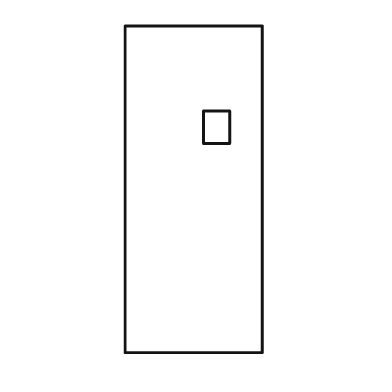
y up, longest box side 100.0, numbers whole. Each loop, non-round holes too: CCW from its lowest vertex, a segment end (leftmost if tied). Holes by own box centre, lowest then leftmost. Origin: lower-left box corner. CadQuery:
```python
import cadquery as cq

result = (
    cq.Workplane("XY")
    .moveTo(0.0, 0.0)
    .lineTo(42.0, 0.0)
    .lineTo(42.0, 100.0)
    .lineTo(0.0, 100.0)
    .close()
    .moveTo(24.0, 64.0)
    .lineTo(32.0, 64.0)
    .lineTo(32.0, 74.0)
    .lineTo(24.0, 74.0)
    .close()
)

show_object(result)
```